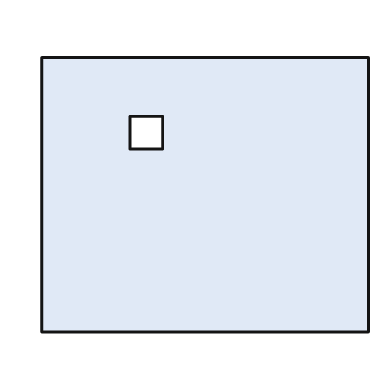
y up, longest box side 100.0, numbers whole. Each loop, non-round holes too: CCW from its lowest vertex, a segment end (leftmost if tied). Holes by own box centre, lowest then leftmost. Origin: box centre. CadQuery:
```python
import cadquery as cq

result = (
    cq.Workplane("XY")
    .moveTo(-50.0, -42.0)
    .lineTo(50.0, -42.0)
    .lineTo(50.0, 42.0)
    .lineTo(-50.0, 42.0)
    .close()
    .moveTo(-23.0, 14.0)
    .lineTo(-13.0, 14.0)
    .lineTo(-13.0, 24.0)
    .lineTo(-23.0, 24.0)
    .close()
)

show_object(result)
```